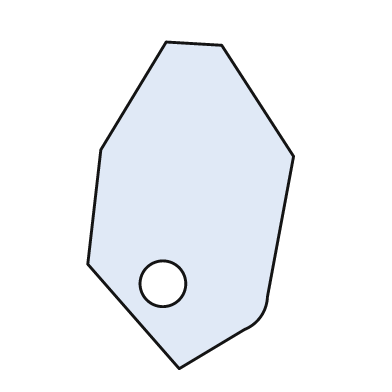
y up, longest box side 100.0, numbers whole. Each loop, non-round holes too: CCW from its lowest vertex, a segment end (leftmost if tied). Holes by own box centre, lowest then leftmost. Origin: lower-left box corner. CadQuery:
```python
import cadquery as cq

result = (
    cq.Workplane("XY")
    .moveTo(28.0, 0.0)
    .lineTo(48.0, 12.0)
    .threePointArc((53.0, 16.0), (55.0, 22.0))
    .lineTo(63.0, 65.0)
    .lineTo(41.0, 99.0)
    .lineTo(24.0, 100.0)
    .lineTo(4.0, 67.0)
    .lineTo(0.0, 32.0)
    .close()
    .moveTo(23.0, 26.0)
    .circle(7.0)
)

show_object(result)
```